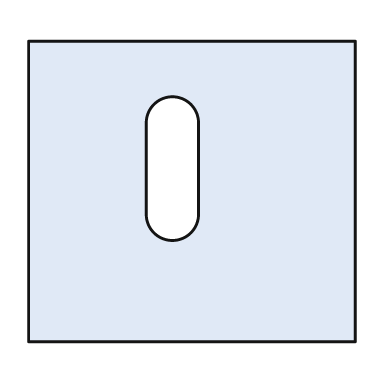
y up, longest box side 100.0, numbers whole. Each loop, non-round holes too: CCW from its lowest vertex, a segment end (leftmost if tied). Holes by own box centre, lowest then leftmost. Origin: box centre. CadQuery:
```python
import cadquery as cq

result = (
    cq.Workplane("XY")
    .moveTo(-50.0, -46.0)
    .lineTo(50.0, -46.0)
    .lineTo(50.0, 46.0)
    .lineTo(-50.0, 46.0)
    .close()
    .moveTo(-14.0, -7.0)
    .threePointArc((-6.0, -15.0), (2.0, -7.0))
    .lineTo(2.0, 21.0)
    .threePointArc((-6.0, 29.0), (-14.0, 21.0))
    .close()
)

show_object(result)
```